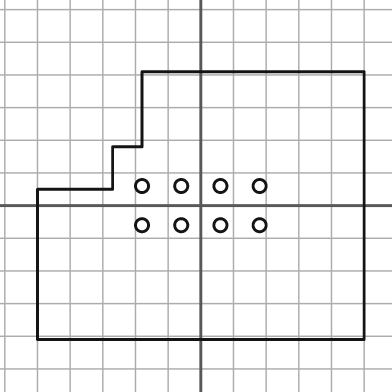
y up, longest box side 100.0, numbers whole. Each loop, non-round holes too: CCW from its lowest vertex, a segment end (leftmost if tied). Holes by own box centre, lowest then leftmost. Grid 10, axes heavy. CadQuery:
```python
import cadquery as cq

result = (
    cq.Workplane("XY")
    .moveTo(-50.0, -41.0)
    .lineTo(50.0, -41.0)
    .lineTo(50.0, 41.0)
    .lineTo(-18.0, 41.0)
    .lineTo(-18.0, 18.0)
    .lineTo(-27.0, 18.0)
    .lineTo(-27.0, 5.0)
    .lineTo(-50.0, 5.0)
    .close()
    .moveTo(-18.0, -6.0)
    .circle(2.0)
    .moveTo(-6.0, -6.0)
    .circle(2.0)
    .moveTo(6.0, -6.0)
    .circle(2.0)
    .moveTo(18.0, -6.0)
    .circle(2.0)
    .moveTo(-18.0, 6.0)
    .circle(2.0)
    .moveTo(-6.0, 6.0)
    .circle(2.0)
    .moveTo(6.0, 6.0)
    .circle(2.0)
    .moveTo(18.0, 6.0)
    .circle(2.0)
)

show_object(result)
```